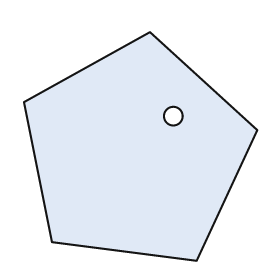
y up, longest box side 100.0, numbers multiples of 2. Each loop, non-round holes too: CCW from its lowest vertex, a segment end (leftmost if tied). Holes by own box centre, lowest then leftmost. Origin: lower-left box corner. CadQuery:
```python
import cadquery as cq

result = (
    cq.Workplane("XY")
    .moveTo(74.0, 0.0)
    .lineTo(100.0, 56.0)
    .lineTo(54.0, 98.0)
    .lineTo(0.0, 68.0)
    .lineTo(12.0, 8.0)
    .close()
    .moveTo(64.0, 62.0)
    .circle(4.0)
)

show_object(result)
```